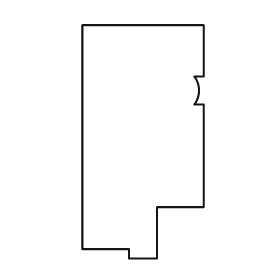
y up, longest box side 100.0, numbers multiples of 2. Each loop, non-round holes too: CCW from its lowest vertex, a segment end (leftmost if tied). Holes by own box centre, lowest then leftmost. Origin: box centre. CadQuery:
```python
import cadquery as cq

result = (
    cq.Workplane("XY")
    .moveTo(-6.0, -50.0)
    .lineTo(6.0, -50.0)
    .lineTo(6.0, -28.0)
    .lineTo(26.0, -28.0)
    .lineTo(26.0, 16.0)
    .lineTo(22.0, 16.0)
    .threePointArc((24.0, 22.0), (22.0, 28.0))
    .lineTo(26.0, 28.0)
    .lineTo(26.0, 50.0)
    .lineTo(-26.0, 50.0)
    .lineTo(-26.0, -46.0)
    .lineTo(-6.0, -46.0)
    .close()
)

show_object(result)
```